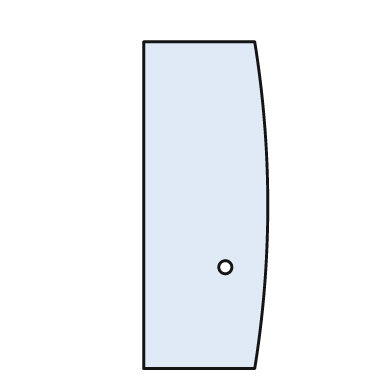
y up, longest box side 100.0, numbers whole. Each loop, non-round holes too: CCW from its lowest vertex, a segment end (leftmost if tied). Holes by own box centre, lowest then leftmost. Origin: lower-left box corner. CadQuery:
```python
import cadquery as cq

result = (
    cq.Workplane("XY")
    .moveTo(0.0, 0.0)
    .lineTo(34.0, 0.0)
    .threePointArc((38.0, 50.0), (34.0, 100.0))
    .lineTo(0.0, 100.0)
    .close()
    .moveTo(25.0, 31.0)
    .circle(2.0)
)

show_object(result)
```